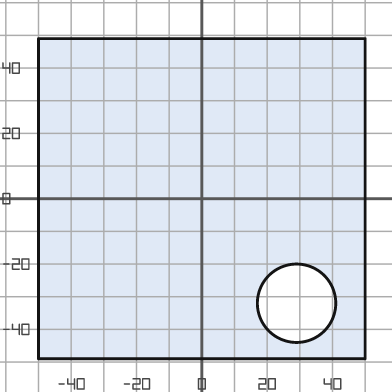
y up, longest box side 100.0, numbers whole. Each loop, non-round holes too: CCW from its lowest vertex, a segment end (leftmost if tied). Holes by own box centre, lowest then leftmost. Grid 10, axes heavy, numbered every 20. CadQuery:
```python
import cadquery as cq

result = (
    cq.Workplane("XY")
    .moveTo(-50.0, -49.0)
    .lineTo(50.0, -49.0)
    .lineTo(50.0, 49.0)
    .lineTo(-50.0, 49.0)
    .close()
    .moveTo(29.0, -32.0)
    .circle(12.0)
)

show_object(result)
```